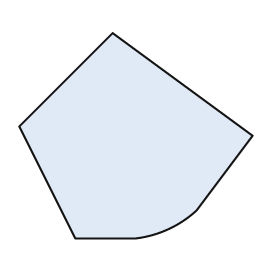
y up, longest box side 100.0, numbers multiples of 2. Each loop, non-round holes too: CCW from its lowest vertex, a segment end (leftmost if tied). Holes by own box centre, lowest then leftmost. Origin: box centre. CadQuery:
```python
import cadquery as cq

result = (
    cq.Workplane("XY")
    .moveTo(-26.0, -44.0)
    .lineTo(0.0, -44.0)
    .threePointArc((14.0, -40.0), (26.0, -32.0))
    .lineTo(50.0, 0.0)
    .lineTo(-10.0, 44.0)
    .lineTo(-50.0, 4.0)
    .close()
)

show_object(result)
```